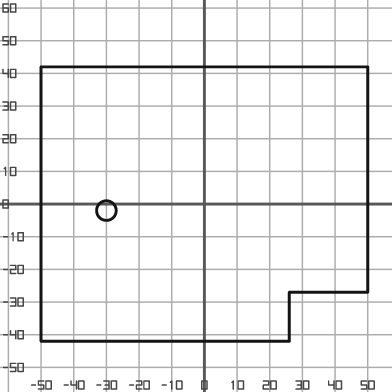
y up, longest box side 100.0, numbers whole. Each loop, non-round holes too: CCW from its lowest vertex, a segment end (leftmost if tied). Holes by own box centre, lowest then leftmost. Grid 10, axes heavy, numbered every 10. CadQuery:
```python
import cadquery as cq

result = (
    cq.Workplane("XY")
    .moveTo(-50.0, -42.0)
    .lineTo(26.0, -42.0)
    .lineTo(26.0, -27.0)
    .lineTo(50.0, -27.0)
    .lineTo(50.0, 42.0)
    .lineTo(-50.0, 42.0)
    .close()
    .moveTo(-30.0, -2.0)
    .circle(3.0)
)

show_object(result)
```